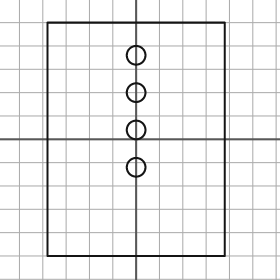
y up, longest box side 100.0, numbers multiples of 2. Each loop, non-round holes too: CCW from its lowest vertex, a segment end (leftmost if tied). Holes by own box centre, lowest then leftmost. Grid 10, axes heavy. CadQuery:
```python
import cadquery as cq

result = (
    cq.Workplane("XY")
    .moveTo(-38.0, -50.0)
    .lineTo(38.0, -50.0)
    .lineTo(38.0, 50.0)
    .lineTo(-38.0, 50.0)
    .close()
    .moveTo(0.0, -12.0)
    .circle(4.0)
    .moveTo(0.0, 4.0)
    .circle(4.0)
    .moveTo(0.0, 20.0)
    .circle(4.0)
    .moveTo(0.0, 36.0)
    .circle(4.0)
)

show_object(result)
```